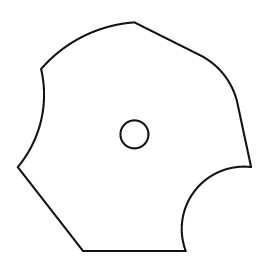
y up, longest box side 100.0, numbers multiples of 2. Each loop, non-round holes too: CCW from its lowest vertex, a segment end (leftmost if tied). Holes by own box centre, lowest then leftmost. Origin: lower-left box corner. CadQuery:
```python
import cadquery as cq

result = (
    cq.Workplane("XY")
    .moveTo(28.0, 0.0)
    .lineTo(72.0, 0.0)
    .threePointArc((76.0, 26.0), (100.0, 36.0))
    .lineTo(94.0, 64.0)
    .threePointArc((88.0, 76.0), (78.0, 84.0))
    .lineTo(50.0, 98.0)
    .threePointArc((28.0, 92.0), (10.0, 78.0))
    .threePointArc((10.0, 56.0), (0.0, 36.0))
    .close()
    .moveTo(50.0, 50.0)
    .circle(6.0)
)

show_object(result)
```